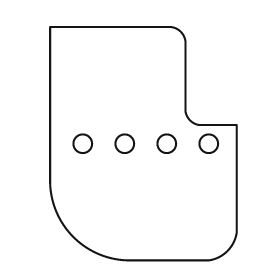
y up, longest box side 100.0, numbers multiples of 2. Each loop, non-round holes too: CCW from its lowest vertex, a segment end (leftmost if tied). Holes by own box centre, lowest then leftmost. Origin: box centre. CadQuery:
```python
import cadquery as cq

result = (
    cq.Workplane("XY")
    .moveTo(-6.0, -50.0)
    .lineTo(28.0, -50.0)
    .threePointArc((36.0, -46.0), (40.0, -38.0))
    .lineTo(40.0, 8.0)
    .lineTo(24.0, 8.0)
    .threePointArc((20.0, 10.0), (18.0, 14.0))
    .lineTo(18.0, 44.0)
    .threePointArc((16.0, 48.0), (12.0, 50.0))
    .lineTo(-40.0, 50.0)
    .lineTo(-40.0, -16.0)
    .threePointArc((-30.0, -40.0), (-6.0, -50.0))
    .close()
    .moveTo(-26.0, 0.0)
    .circle(4.0)
    .moveTo(-8.0, 0.0)
    .circle(4.0)
    .moveTo(10.0, 0.0)
    .circle(4.0)
    .moveTo(28.0, 0.0)
    .circle(4.0)
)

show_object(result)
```